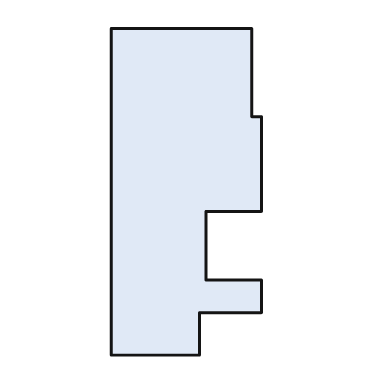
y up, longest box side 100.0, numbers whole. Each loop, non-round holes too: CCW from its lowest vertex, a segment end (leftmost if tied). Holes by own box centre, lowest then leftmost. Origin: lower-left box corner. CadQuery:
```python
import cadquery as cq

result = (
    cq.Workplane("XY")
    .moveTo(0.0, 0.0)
    .lineTo(27.0, 0.0)
    .lineTo(27.0, 13.0)
    .lineTo(46.0, 13.0)
    .lineTo(46.0, 23.0)
    .lineTo(29.0, 23.0)
    .lineTo(29.0, 44.0)
    .lineTo(46.0, 44.0)
    .lineTo(46.0, 73.0)
    .lineTo(43.0, 73.0)
    .lineTo(43.0, 100.0)
    .lineTo(0.0, 100.0)
    .close()
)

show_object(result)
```